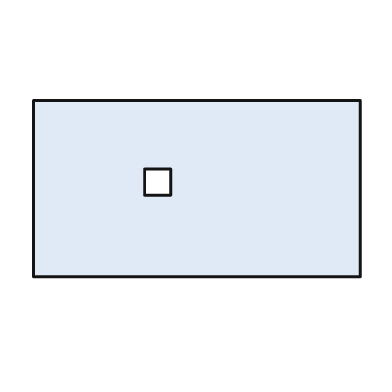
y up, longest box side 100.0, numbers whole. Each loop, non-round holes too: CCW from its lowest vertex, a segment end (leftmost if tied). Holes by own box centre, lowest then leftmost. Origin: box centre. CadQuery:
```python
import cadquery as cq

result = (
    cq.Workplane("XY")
    .moveTo(-50.0, -27.0)
    .lineTo(50.0, -27.0)
    .lineTo(50.0, 27.0)
    .lineTo(-50.0, 27.0)
    .close()
    .moveTo(-16.0, -2.0)
    .lineTo(-8.0, -2.0)
    .lineTo(-8.0, 6.0)
    .lineTo(-16.0, 6.0)
    .close()
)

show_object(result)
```